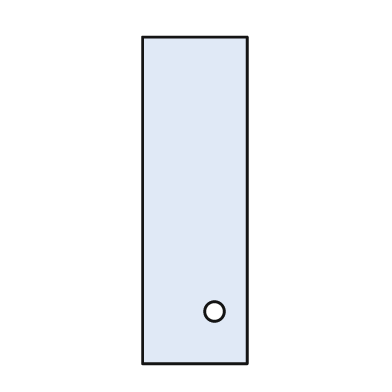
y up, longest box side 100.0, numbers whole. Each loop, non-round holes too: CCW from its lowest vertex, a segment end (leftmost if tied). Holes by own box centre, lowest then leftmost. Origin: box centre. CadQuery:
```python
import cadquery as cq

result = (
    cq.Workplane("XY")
    .moveTo(-16.0, -50.0)
    .lineTo(16.0, -50.0)
    .lineTo(16.0, 50.0)
    .lineTo(-16.0, 50.0)
    .close()
    .moveTo(6.0, -34.0)
    .circle(3.0)
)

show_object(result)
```